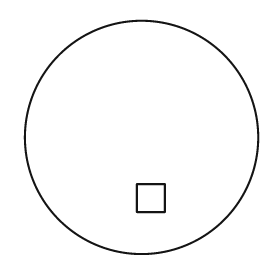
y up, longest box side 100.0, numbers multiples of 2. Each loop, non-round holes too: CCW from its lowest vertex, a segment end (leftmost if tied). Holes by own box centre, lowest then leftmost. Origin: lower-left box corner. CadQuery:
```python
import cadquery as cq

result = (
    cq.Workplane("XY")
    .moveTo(50.0, 50.0)
    .circle(50.0)
    .moveTo(48.0, 18.0)
    .lineTo(60.0, 18.0)
    .lineTo(60.0, 30.0)
    .lineTo(48.0, 30.0)
    .close()
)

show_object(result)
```